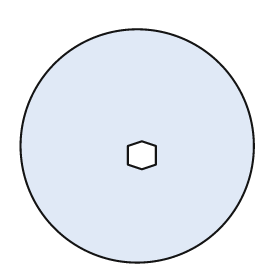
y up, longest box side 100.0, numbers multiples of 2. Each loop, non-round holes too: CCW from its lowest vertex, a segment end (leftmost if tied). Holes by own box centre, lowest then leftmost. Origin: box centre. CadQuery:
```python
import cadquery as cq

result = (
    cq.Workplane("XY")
    .moveTo(0.0, 0.0)
    .circle(50.0)
    .moveTo(2.0, -10.0)
    .lineTo(8.0, -8.0)
    .lineTo(8.0, 0.0)
    .lineTo(2.0, 2.0)
    .lineTo(-4.0, 0.0)
    .lineTo(-4.0, -8.0)
    .close()
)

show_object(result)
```